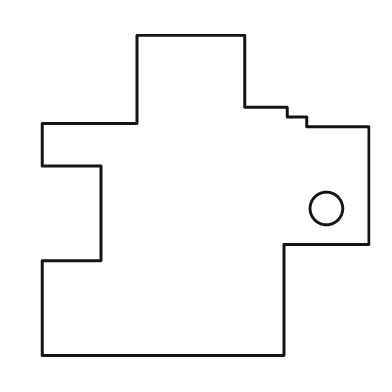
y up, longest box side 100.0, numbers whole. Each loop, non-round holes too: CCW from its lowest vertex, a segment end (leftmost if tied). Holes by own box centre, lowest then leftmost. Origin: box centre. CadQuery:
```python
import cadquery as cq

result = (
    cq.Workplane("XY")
    .moveTo(-50.0, -49.0)
    .lineTo(24.0, -49.0)
    .lineTo(24.0, -15.0)
    .lineTo(50.0, -15.0)
    .lineTo(50.0, 21.0)
    .lineTo(31.0, 21.0)
    .lineTo(31.0, 24.0)
    .lineTo(25.0, 24.0)
    .lineTo(25.0, 27.0)
    .lineTo(12.0, 27.0)
    .lineTo(12.0, 49.0)
    .lineTo(-21.0, 49.0)
    .lineTo(-21.0, 22.0)
    .lineTo(-50.0, 22.0)
    .lineTo(-50.0, 9.0)
    .lineTo(-32.0, 9.0)
    .lineTo(-32.0, -20.0)
    .lineTo(-50.0, -20.0)
    .close()
    .moveTo(37.0, -4.0)
    .circle(5.0)
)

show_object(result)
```